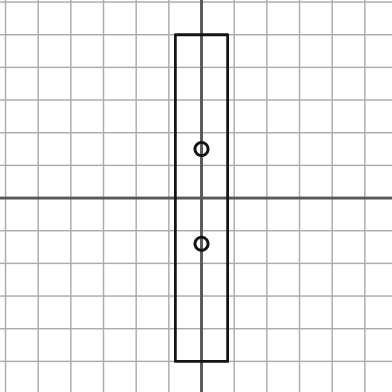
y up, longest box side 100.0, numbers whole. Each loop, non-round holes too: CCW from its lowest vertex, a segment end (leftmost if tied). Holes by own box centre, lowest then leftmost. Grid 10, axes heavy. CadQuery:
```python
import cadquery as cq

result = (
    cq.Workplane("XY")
    .moveTo(-8.0, -50.0)
    .lineTo(8.0, -50.0)
    .lineTo(8.0, 50.0)
    .lineTo(-8.0, 50.0)
    .close()
    .moveTo(0.0, -14.0)
    .circle(2.0)
    .moveTo(0.0, 15.0)
    .circle(2.0)
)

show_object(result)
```